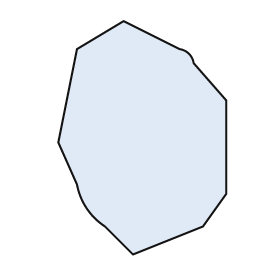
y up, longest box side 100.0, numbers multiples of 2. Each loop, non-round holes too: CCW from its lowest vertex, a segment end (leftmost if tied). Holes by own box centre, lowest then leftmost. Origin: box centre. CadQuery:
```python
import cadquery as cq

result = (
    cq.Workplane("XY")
    .moveTo(-4.0, -50.0)
    .lineTo(26.0, -38.0)
    .lineTo(36.0, -24.0)
    .lineTo(36.0, 16.0)
    .lineTo(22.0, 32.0)
    .threePointArc((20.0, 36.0), (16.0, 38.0))
    .lineTo(-8.0, 50.0)
    .lineTo(-28.0, 38.0)
    .lineTo(-36.0, -2.0)
    .lineTo(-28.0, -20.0)
    .threePointArc((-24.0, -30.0), (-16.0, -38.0))
    .close()
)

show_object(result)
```